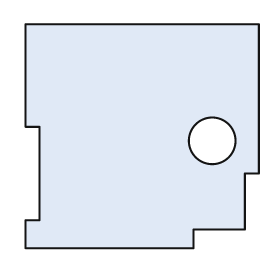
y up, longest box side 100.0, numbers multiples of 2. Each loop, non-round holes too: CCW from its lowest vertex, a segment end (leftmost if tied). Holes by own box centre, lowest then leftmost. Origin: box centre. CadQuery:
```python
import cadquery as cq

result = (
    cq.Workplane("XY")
    .moveTo(-50.0, -48.0)
    .lineTo(22.0, -48.0)
    .lineTo(22.0, -40.0)
    .lineTo(44.0, -40.0)
    .lineTo(44.0, -16.0)
    .lineTo(50.0, -16.0)
    .lineTo(50.0, 48.0)
    .lineTo(-50.0, 48.0)
    .lineTo(-50.0, 4.0)
    .lineTo(-44.0, 4.0)
    .lineTo(-44.0, -36.0)
    .lineTo(-50.0, -36.0)
    .close()
    .moveTo(30.0, -2.0)
    .circle(10.0)
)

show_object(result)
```